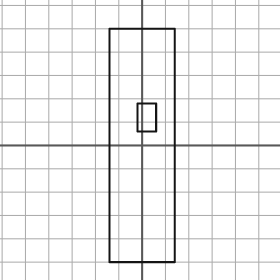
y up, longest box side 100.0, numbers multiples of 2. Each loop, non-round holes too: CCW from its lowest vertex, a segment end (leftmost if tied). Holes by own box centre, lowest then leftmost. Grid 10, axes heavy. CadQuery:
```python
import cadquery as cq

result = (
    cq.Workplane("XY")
    .moveTo(-14.0, -50.0)
    .lineTo(14.0, -50.0)
    .lineTo(14.0, 50.0)
    .lineTo(-14.0, 50.0)
    .close()
    .moveTo(-2.0, 6.0)
    .lineTo(6.0, 6.0)
    .lineTo(6.0, 18.0)
    .lineTo(-2.0, 18.0)
    .close()
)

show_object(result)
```